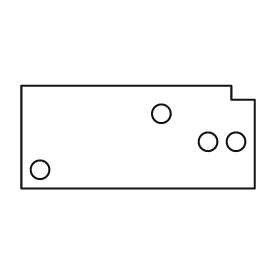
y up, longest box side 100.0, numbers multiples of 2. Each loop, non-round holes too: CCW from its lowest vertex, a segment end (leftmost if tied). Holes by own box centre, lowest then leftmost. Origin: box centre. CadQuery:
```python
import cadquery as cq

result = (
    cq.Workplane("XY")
    .moveTo(-50.0, -22.0)
    .lineTo(50.0, -22.0)
    .lineTo(50.0, 16.0)
    .lineTo(40.0, 16.0)
    .lineTo(40.0, 22.0)
    .lineTo(-50.0, 22.0)
    .close()
    .moveTo(-42.0, -14.0)
    .circle(4.0)
    .moveTo(30.0, -2.0)
    .circle(4.0)
    .moveTo(42.0, -2.0)
    .circle(4.0)
    .moveTo(10.0, 10.0)
    .circle(4.0)
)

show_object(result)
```